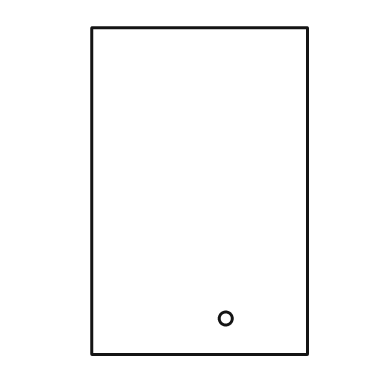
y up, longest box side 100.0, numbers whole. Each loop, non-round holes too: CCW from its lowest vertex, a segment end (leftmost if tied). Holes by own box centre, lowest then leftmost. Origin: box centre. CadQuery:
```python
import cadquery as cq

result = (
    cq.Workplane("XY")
    .moveTo(-33.0, -50.0)
    .lineTo(33.0, -50.0)
    .lineTo(33.0, 50.0)
    .lineTo(-33.0, 50.0)
    .close()
    .moveTo(8.0, -39.0)
    .circle(2.0)
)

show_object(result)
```